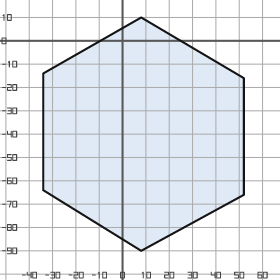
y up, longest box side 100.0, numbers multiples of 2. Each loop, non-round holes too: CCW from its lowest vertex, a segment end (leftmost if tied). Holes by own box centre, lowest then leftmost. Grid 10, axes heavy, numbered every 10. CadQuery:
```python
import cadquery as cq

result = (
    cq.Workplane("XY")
    .moveTo(8.0, -90.0)
    .lineTo(52.0, -66.0)
    .lineTo(52.0, -16.0)
    .lineTo(8.0, 10.0)
    .lineTo(-34.0, -14.0)
    .lineTo(-34.0, -64.0)
    .close()
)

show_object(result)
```